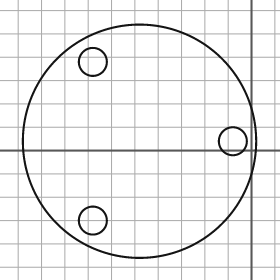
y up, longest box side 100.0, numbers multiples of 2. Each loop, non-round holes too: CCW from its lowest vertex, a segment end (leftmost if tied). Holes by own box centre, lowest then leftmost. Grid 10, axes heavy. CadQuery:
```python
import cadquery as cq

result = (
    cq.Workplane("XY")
    .moveTo(-48.0, 4.0)
    .circle(50.0)
    .moveTo(-68.0, -30.0)
    .circle(6.0)
    .moveTo(-8.0, 4.0)
    .circle(6.0)
    .moveTo(-68.0, 38.0)
    .circle(6.0)
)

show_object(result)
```